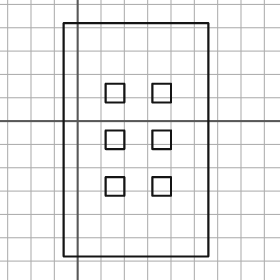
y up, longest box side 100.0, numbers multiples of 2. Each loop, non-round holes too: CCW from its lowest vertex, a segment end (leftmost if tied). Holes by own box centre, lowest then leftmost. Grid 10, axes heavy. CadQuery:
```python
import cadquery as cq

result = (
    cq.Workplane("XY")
    .moveTo(-6.0, -58.0)
    .lineTo(56.0, -58.0)
    .lineTo(56.0, 42.0)
    .lineTo(-6.0, 42.0)
    .close()
    .moveTo(12.0, -32.0)
    .lineTo(20.0, -32.0)
    .lineTo(20.0, -24.0)
    .lineTo(12.0, -24.0)
    .close()
    .moveTo(32.0, -32.0)
    .lineTo(40.0, -32.0)
    .lineTo(40.0, -24.0)
    .lineTo(32.0, -24.0)
    .close()
    .moveTo(12.0, -12.0)
    .lineTo(20.0, -12.0)
    .lineTo(20.0, -4.0)
    .lineTo(12.0, -4.0)
    .close()
    .moveTo(32.0, -12.0)
    .lineTo(40.0, -12.0)
    .lineTo(40.0, -4.0)
    .lineTo(32.0, -4.0)
    .close()
    .moveTo(12.0, 8.0)
    .lineTo(20.0, 8.0)
    .lineTo(20.0, 16.0)
    .lineTo(12.0, 16.0)
    .close()
    .moveTo(32.0, 8.0)
    .lineTo(40.0, 8.0)
    .lineTo(40.0, 16.0)
    .lineTo(32.0, 16.0)
    .close()
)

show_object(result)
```